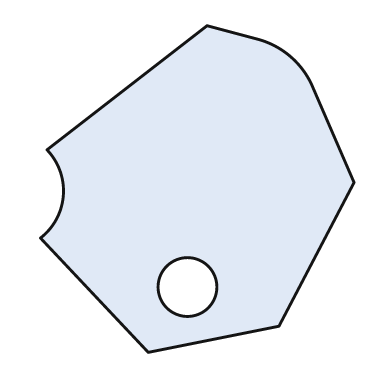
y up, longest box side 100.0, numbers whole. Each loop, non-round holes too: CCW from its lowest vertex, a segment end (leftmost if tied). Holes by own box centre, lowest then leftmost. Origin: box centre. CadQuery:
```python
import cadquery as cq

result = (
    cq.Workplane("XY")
    .moveTo(-15.0, -50.0)
    .lineTo(25.0, -42.0)
    .lineTo(48.0, 2.0)
    .lineTo(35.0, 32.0)
    .threePointArc((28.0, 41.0), (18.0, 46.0))
    .lineTo(3.0, 50.0)
    .lineTo(-46.0, 12.0)
    .threePointArc((-41.0, -2.0), (-48.0, -15.0))
    .close()
    .moveTo(-3.0, -30.0)
    .circle(9.0)
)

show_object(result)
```